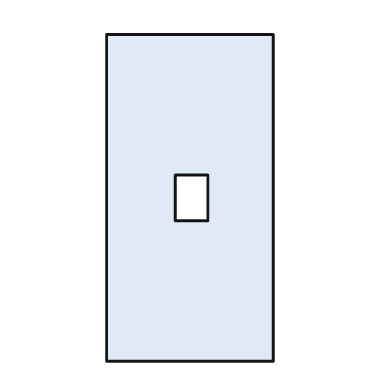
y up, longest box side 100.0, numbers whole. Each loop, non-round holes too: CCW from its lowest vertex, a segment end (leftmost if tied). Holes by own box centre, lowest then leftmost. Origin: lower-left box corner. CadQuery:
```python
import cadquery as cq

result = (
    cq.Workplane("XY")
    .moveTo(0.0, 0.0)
    .lineTo(51.0, 0.0)
    .lineTo(51.0, 100.0)
    .lineTo(0.0, 100.0)
    .close()
    .moveTo(21.0, 43.0)
    .lineTo(31.0, 43.0)
    .lineTo(31.0, 57.0)
    .lineTo(21.0, 57.0)
    .close()
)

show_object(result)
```